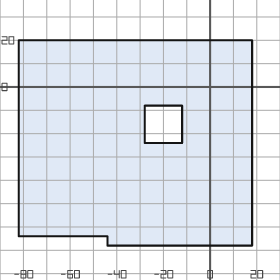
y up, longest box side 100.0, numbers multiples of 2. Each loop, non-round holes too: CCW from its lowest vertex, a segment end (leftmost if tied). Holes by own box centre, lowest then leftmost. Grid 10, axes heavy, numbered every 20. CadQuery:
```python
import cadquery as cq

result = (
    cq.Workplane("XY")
    .moveTo(-44.0, -68.0)
    .lineTo(18.0, -68.0)
    .lineTo(18.0, 20.0)
    .lineTo(-82.0, 20.0)
    .lineTo(-82.0, -64.0)
    .lineTo(-44.0, -64.0)
    .close()
    .moveTo(-28.0, -24.0)
    .lineTo(-12.0, -24.0)
    .lineTo(-12.0, -8.0)
    .lineTo(-28.0, -8.0)
    .close()
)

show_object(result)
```